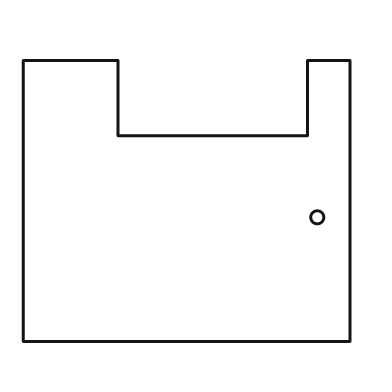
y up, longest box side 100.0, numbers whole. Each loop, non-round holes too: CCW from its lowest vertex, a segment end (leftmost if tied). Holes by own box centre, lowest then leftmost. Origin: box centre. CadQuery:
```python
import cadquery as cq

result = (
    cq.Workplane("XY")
    .moveTo(-50.0, -43.0)
    .lineTo(50.0, -43.0)
    .lineTo(50.0, 43.0)
    .lineTo(37.0, 43.0)
    .lineTo(37.0, 20.0)
    .lineTo(-21.0, 20.0)
    .lineTo(-21.0, 43.0)
    .lineTo(-50.0, 43.0)
    .close()
    .moveTo(40.0, -5.0)
    .circle(2.0)
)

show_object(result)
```